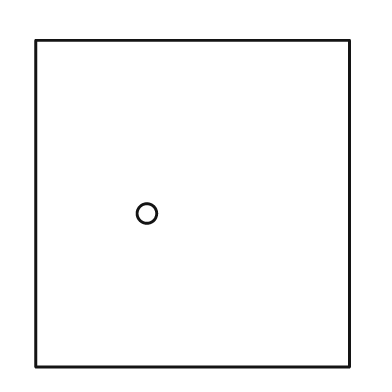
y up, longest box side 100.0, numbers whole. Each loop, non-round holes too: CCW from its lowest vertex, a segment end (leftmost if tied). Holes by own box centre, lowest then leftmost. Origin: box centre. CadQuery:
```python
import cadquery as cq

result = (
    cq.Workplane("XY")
    .moveTo(-48.0, -50.0)
    .lineTo(48.0, -50.0)
    .lineTo(48.0, 50.0)
    .lineTo(-48.0, 50.0)
    .close()
    .moveTo(-14.0, -3.0)
    .circle(3.0)
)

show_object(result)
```